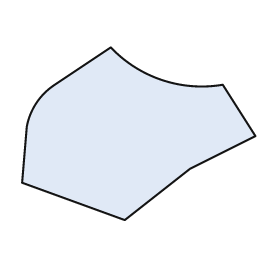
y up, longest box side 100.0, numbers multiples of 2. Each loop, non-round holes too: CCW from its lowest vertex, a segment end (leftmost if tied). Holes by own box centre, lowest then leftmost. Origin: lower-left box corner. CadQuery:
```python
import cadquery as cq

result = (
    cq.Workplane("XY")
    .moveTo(44.0, 0.0)
    .lineTo(72.0, 22.0)
    .lineTo(100.0, 36.0)
    .lineTo(86.0, 58.0)
    .threePointArc((60.0, 60.0), (38.0, 74.0))
    .lineTo(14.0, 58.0)
    .threePointArc((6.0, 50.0), (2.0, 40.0))
    .lineTo(0.0, 16.0)
    .close()
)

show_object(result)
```